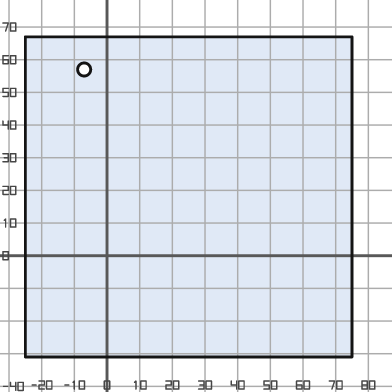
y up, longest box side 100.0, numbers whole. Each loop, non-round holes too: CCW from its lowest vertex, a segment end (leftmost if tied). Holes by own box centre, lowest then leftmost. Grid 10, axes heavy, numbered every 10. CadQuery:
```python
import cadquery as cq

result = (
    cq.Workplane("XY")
    .moveTo(-25.0, -31.0)
    .lineTo(75.0, -31.0)
    .lineTo(75.0, 67.0)
    .lineTo(-25.0, 67.0)
    .close()
    .moveTo(-7.0, 57.0)
    .circle(2.0)
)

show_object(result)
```